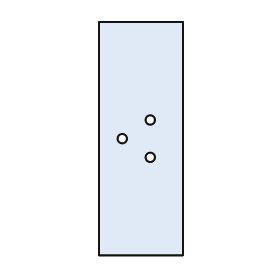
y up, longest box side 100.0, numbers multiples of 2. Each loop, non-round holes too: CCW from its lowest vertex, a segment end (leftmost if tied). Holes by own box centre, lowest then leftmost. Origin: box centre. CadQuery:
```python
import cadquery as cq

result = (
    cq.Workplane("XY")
    .moveTo(-18.0, -50.0)
    .lineTo(18.0, -50.0)
    .lineTo(18.0, 50.0)
    .lineTo(-18.0, 50.0)
    .close()
    .moveTo(4.0, -8.0)
    .circle(2.0)
    .moveTo(-8.0, 0.0)
    .circle(2.0)
    .moveTo(4.0, 8.0)
    .circle(2.0)
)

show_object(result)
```